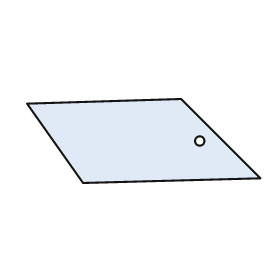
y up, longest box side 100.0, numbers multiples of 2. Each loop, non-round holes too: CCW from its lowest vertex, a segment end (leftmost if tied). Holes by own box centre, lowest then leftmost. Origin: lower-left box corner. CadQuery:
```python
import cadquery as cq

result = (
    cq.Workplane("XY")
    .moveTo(24.0, 0.0)
    .lineTo(100.0, 2.0)
    .lineTo(66.0, 36.0)
    .lineTo(0.0, 34.0)
    .close()
    .moveTo(74.0, 18.0)
    .circle(2.0)
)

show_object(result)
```